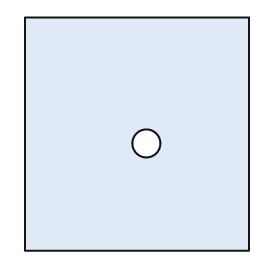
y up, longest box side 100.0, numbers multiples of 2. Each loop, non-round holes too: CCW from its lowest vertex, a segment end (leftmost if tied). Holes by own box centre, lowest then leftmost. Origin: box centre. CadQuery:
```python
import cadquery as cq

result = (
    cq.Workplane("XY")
    .moveTo(-48.0, -50.0)
    .lineTo(48.0, -50.0)
    .lineTo(48.0, 50.0)
    .lineTo(-48.0, 50.0)
    .close()
    .moveTo(4.0, -4.0)
    .circle(6.0)
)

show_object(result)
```